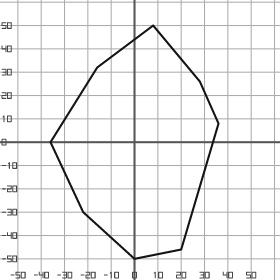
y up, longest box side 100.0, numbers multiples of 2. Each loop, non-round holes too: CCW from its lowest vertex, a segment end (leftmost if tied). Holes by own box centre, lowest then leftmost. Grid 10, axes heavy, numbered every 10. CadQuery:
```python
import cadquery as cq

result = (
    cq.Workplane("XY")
    .moveTo(0.0, -50.0)
    .lineTo(20.0, -46.0)
    .lineTo(36.0, 8.0)
    .lineTo(28.0, 26.0)
    .lineTo(8.0, 50.0)
    .lineTo(-16.0, 32.0)
    .lineTo(-36.0, 0.0)
    .lineTo(-22.0, -30.0)
    .close()
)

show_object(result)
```